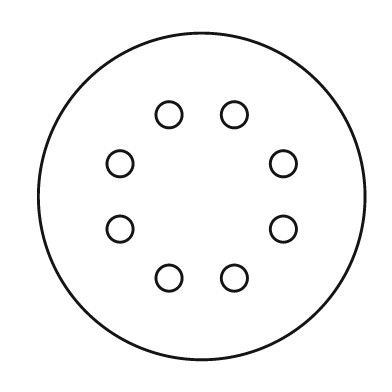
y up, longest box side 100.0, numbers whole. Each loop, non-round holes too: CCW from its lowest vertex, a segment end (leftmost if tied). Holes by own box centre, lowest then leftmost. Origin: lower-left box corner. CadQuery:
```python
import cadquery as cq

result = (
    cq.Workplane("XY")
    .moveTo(50.0, 50.0)
    .circle(50.0)
    .moveTo(40.0, 25.0)
    .circle(4.0)
    .moveTo(60.0, 25.0)
    .circle(4.0)
    .moveTo(25.0, 40.0)
    .circle(4.0)
    .moveTo(75.0, 40.0)
    .circle(4.0)
    .moveTo(25.0, 60.0)
    .circle(4.0)
    .moveTo(75.0, 60.0)
    .circle(4.0)
    .moveTo(40.0, 75.0)
    .circle(4.0)
    .moveTo(60.0, 75.0)
    .circle(4.0)
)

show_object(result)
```